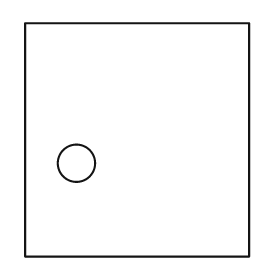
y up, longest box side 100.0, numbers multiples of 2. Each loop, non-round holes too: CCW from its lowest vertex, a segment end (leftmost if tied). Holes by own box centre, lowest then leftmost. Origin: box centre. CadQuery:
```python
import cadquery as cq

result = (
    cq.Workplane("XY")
    .moveTo(-48.0, -50.0)
    .lineTo(48.0, -50.0)
    .lineTo(48.0, 50.0)
    .lineTo(-48.0, 50.0)
    .close()
    .moveTo(-26.0, -10.0)
    .circle(8.0)
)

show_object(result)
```